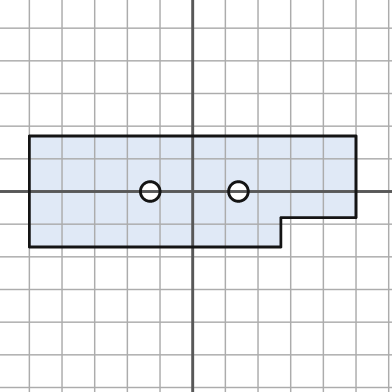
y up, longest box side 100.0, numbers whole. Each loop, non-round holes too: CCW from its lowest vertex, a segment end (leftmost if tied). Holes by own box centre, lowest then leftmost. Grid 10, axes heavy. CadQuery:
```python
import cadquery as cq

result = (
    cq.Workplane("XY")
    .moveTo(-50.0, -17.0)
    .lineTo(27.0, -17.0)
    .lineTo(27.0, -8.0)
    .lineTo(50.0, -8.0)
    .lineTo(50.0, 17.0)
    .lineTo(-50.0, 17.0)
    .close()
    .moveTo(-13.0, 0.0)
    .circle(3.0)
    .moveTo(14.0, 0.0)
    .circle(3.0)
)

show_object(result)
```